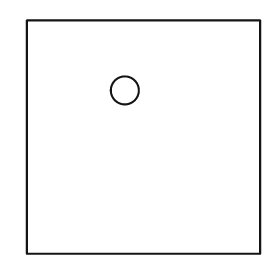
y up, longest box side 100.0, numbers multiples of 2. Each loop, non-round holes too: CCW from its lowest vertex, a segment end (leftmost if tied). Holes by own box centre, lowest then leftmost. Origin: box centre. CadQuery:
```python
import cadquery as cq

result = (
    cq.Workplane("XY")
    .moveTo(-50.0, -50.0)
    .lineTo(50.0, -50.0)
    .lineTo(50.0, 50.0)
    .lineTo(-50.0, 50.0)
    .close()
    .moveTo(-8.0, 20.0)
    .circle(6.0)
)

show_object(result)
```